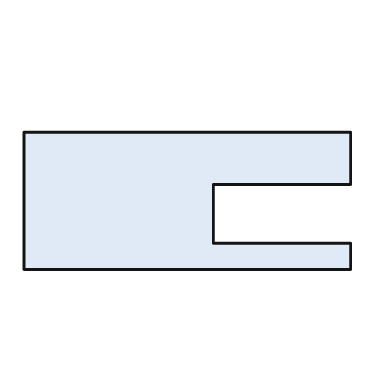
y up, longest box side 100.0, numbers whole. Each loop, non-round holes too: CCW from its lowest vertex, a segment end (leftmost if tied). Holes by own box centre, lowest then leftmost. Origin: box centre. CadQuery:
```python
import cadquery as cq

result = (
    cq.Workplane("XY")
    .moveTo(-50.0, -21.0)
    .lineTo(50.0, -21.0)
    .lineTo(50.0, -13.0)
    .lineTo(8.0, -13.0)
    .lineTo(8.0, 5.0)
    .lineTo(50.0, 5.0)
    .lineTo(50.0, 21.0)
    .lineTo(-50.0, 21.0)
    .close()
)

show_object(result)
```